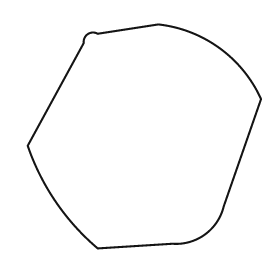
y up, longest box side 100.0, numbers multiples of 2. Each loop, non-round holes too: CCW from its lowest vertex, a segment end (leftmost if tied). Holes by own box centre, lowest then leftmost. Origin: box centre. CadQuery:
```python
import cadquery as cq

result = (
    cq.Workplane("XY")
    .moveTo(-20.0, -48.0)
    .lineTo(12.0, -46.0)
    .threePointArc((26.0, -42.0), (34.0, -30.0))
    .lineTo(50.0, 16.0)
    .threePointArc((32.0, 38.0), (6.0, 48.0))
    .lineTo(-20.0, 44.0)
    .threePointArc((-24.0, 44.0), (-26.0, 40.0))
    .lineTo(-50.0, -4.0)
    .threePointArc((-38.0, -28.0), (-20.0, -48.0))
    .close()
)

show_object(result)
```